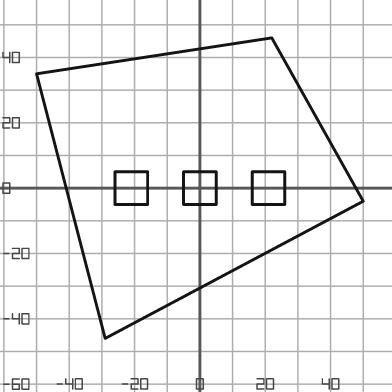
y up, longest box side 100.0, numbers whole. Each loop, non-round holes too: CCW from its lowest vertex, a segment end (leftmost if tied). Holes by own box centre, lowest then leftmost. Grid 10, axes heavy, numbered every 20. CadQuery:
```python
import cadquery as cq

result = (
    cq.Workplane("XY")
    .moveTo(-29.0, -46.0)
    .lineTo(50.0, -4.0)
    .lineTo(22.0, 46.0)
    .lineTo(-50.0, 35.0)
    .close()
    .moveTo(-26.0, -5.0)
    .lineTo(-16.0, -5.0)
    .lineTo(-16.0, 5.0)
    .lineTo(-26.0, 5.0)
    .close()
    .moveTo(-5.0, -5.0)
    .lineTo(5.0, -5.0)
    .lineTo(5.0, 5.0)
    .lineTo(-5.0, 5.0)
    .close()
    .moveTo(16.0, -5.0)
    .lineTo(26.0, -5.0)
    .lineTo(26.0, 5.0)
    .lineTo(16.0, 5.0)
    .close()
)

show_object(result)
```